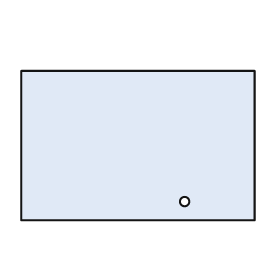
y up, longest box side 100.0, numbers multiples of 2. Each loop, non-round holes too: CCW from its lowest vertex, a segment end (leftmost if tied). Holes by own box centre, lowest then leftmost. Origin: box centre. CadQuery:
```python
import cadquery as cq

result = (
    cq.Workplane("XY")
    .moveTo(-50.0, -32.0)
    .lineTo(50.0, -32.0)
    .lineTo(50.0, 32.0)
    .lineTo(-50.0, 32.0)
    .close()
    .moveTo(20.0, -24.0)
    .circle(2.0)
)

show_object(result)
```